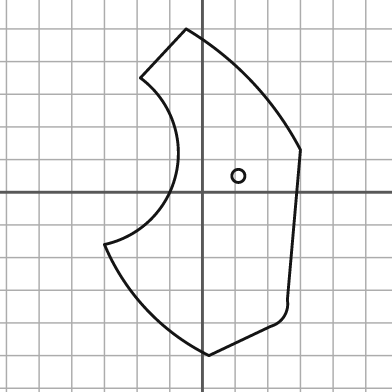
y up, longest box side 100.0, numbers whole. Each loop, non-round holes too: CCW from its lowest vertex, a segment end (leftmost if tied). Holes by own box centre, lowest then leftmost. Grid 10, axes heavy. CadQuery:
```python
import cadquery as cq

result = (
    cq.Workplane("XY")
    .moveTo(2.0, -50.0)
    .lineTo(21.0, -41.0)
    .threePointArc((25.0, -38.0), (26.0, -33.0))
    .lineTo(30.0, 13.0)
    .threePointArc((15.0, 34.0), (-5.0, 50.0))
    .lineTo(-19.0, 35.0)
    .threePointArc((-8.0, 6.0), (-30.0, -16.0))
    .threePointArc((-17.0, -36.0), (2.0, -50.0))
    .close()
    .moveTo(11.0, 5.0)
    .circle(2.0)
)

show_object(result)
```